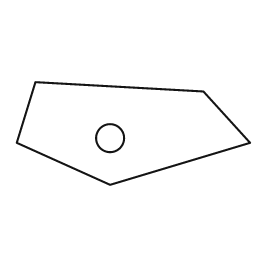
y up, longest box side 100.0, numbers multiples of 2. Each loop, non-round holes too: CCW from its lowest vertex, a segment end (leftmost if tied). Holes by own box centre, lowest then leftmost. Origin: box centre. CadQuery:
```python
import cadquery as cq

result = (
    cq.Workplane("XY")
    .moveTo(-10.0, -22.0)
    .lineTo(50.0, -4.0)
    .lineTo(30.0, 18.0)
    .lineTo(-42.0, 22.0)
    .lineTo(-50.0, -4.0)
    .close()
    .moveTo(-10.0, -2.0)
    .circle(6.0)
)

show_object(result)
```